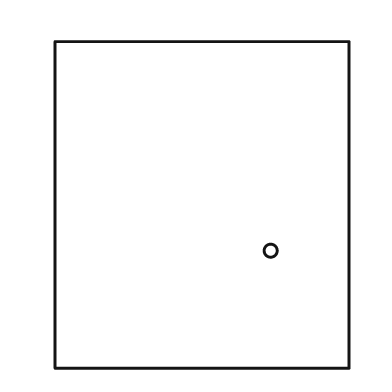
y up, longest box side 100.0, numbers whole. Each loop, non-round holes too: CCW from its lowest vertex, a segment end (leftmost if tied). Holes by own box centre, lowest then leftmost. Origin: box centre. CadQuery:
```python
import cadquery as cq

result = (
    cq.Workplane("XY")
    .moveTo(-45.0, -50.0)
    .lineTo(45.0, -50.0)
    .lineTo(45.0, 50.0)
    .lineTo(-45.0, 50.0)
    .close()
    .moveTo(21.0, -14.0)
    .circle(2.0)
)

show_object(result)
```